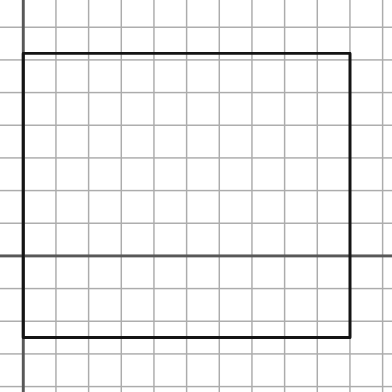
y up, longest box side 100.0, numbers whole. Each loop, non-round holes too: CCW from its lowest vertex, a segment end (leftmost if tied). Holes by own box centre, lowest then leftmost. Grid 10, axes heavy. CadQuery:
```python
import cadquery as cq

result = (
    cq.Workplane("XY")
    .moveTo(0.0, -25.0)
    .lineTo(100.0, -25.0)
    .lineTo(100.0, 62.0)
    .lineTo(0.0, 62.0)
    .close()
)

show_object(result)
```